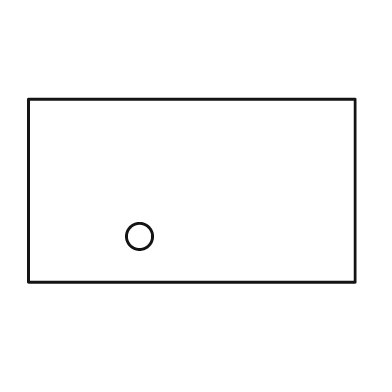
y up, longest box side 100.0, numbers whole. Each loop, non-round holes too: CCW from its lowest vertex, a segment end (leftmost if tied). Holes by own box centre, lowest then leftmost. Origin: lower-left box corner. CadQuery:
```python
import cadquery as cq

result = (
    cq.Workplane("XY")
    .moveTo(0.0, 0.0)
    .lineTo(100.0, 0.0)
    .lineTo(100.0, 56.0)
    .lineTo(0.0, 56.0)
    .close()
    .moveTo(34.0, 14.0)
    .circle(4.0)
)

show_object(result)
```